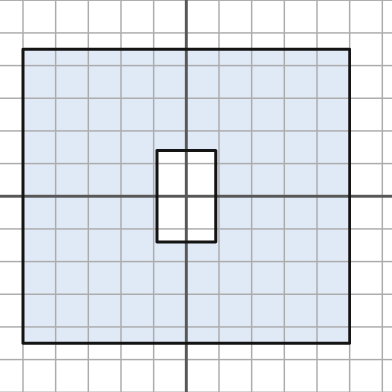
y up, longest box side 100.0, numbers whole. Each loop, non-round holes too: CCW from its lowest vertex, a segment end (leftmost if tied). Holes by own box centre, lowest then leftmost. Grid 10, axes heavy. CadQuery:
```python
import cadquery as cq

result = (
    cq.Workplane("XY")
    .moveTo(-50.0, -45.0)
    .lineTo(50.0, -45.0)
    .lineTo(50.0, 45.0)
    .lineTo(-50.0, 45.0)
    .close()
    .moveTo(-9.0, -14.0)
    .lineTo(9.0, -14.0)
    .lineTo(9.0, 14.0)
    .lineTo(-9.0, 14.0)
    .close()
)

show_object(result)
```